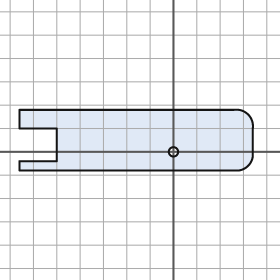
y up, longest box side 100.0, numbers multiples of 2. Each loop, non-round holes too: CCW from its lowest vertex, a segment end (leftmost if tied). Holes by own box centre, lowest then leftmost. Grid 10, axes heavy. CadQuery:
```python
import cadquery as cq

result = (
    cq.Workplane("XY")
    .moveTo(-66.0, -8.0)
    .lineTo(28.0, -8.0)
    .threePointArc((32.0, -6.0), (34.0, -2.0))
    .lineTo(34.0, 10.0)
    .threePointArc((32.0, 16.0), (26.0, 18.0))
    .lineTo(-66.0, 18.0)
    .lineTo(-66.0, 10.0)
    .lineTo(-50.0, 10.0)
    .lineTo(-50.0, -4.0)
    .lineTo(-66.0, -4.0)
    .close()
    .moveTo(0.0, 0.0)
    .circle(2.0)
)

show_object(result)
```